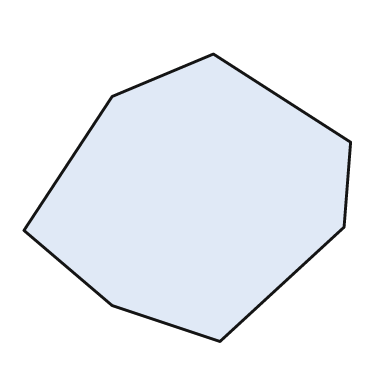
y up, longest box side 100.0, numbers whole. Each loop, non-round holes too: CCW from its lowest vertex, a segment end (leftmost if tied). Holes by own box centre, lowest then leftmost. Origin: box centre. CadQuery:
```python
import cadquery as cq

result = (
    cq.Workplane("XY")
    .moveTo(10.0, -44.0)
    .lineTo(48.0, -9.0)
    .lineTo(50.0, 17.0)
    .lineTo(8.0, 44.0)
    .lineTo(-23.0, 31.0)
    .lineTo(-50.0, -10.0)
    .lineTo(-23.0, -33.0)
    .close()
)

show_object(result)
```